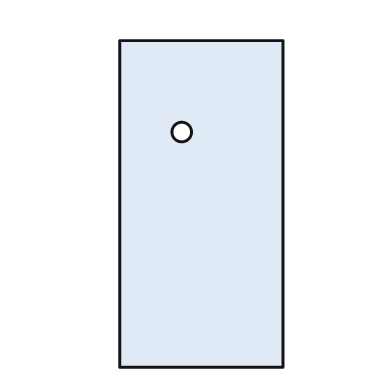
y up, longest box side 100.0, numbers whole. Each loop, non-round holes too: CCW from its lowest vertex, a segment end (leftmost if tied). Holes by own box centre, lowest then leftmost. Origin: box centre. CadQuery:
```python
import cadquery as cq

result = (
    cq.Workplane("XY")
    .moveTo(-25.0, -50.0)
    .lineTo(25.0, -50.0)
    .lineTo(25.0, 50.0)
    .lineTo(-25.0, 50.0)
    .close()
    .moveTo(-6.0, 22.0)
    .circle(3.0)
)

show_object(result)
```